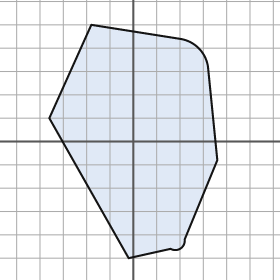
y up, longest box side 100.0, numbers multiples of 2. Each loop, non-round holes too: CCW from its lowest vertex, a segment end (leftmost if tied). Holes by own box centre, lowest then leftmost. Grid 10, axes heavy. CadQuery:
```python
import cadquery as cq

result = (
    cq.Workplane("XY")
    .moveTo(-2.0, -50.0)
    .lineTo(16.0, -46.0)
    .threePointArc((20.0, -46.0), (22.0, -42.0))
    .lineTo(36.0, -8.0)
    .lineTo(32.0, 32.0)
    .threePointArc((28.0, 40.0), (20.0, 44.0))
    .lineTo(-18.0, 50.0)
    .lineTo(-36.0, 10.0)
    .close()
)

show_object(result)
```